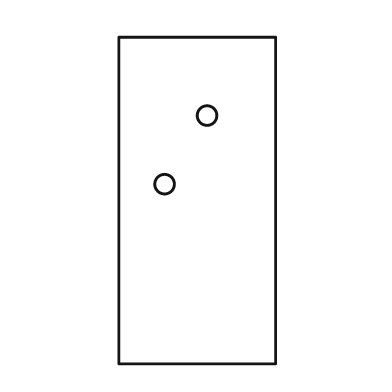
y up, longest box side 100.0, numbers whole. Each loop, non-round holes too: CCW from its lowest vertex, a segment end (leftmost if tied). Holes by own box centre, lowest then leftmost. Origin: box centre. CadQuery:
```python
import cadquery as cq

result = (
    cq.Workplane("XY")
    .moveTo(-24.0, -50.0)
    .lineTo(24.0, -50.0)
    .lineTo(24.0, 50.0)
    .lineTo(-24.0, 50.0)
    .close()
    .moveTo(-10.0, 5.0)
    .circle(3.0)
    .moveTo(3.0, 26.0)
    .circle(3.0)
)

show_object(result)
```